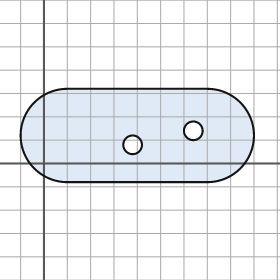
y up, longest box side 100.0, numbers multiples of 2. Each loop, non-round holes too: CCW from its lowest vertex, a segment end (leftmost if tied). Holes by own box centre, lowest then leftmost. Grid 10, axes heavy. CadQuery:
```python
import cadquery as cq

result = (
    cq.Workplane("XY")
    .moveTo(10.0, -8.0)
    .lineTo(70.0, -8.0)
    .threePointArc((90.0, 12.0), (70.0, 32.0))
    .lineTo(10.0, 32.0)
    .threePointArc((-10.0, 12.0), (10.0, -8.0))
    .close()
    .moveTo(38.0, 8.0)
    .circle(4.0)
    .moveTo(64.0, 14.0)
    .circle(4.0)
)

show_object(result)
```